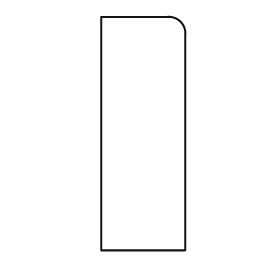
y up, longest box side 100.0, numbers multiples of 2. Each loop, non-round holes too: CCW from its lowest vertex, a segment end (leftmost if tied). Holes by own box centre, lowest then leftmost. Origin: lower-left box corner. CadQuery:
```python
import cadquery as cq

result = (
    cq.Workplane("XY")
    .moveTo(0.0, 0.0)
    .lineTo(36.0, 0.0)
    .lineTo(36.0, 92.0)
    .threePointArc((34.0, 98.0), (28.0, 100.0))
    .lineTo(0.0, 100.0)
    .close()
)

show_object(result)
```